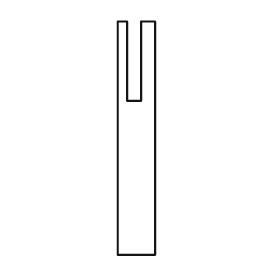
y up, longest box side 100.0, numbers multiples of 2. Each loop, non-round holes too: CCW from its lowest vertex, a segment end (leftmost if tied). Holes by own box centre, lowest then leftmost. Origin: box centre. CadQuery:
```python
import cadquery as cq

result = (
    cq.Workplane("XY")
    .moveTo(-8.0, -50.0)
    .lineTo(8.0, -50.0)
    .lineTo(8.0, 50.0)
    .lineTo(2.0, 50.0)
    .lineTo(2.0, 16.0)
    .lineTo(-4.0, 16.0)
    .lineTo(-4.0, 50.0)
    .lineTo(-8.0, 50.0)
    .close()
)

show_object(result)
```